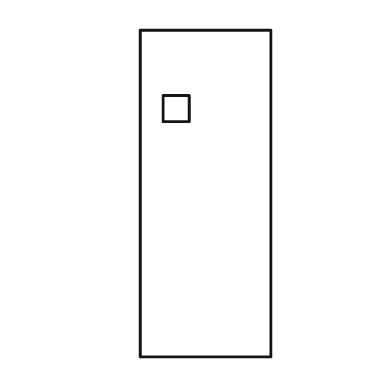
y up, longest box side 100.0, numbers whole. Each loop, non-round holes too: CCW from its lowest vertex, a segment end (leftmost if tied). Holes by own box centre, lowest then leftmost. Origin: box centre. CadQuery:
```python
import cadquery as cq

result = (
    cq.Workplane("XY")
    .moveTo(-20.0, -50.0)
    .lineTo(20.0, -50.0)
    .lineTo(20.0, 50.0)
    .lineTo(-20.0, 50.0)
    .close()
    .moveTo(-13.0, 22.0)
    .lineTo(-5.0, 22.0)
    .lineTo(-5.0, 30.0)
    .lineTo(-13.0, 30.0)
    .close()
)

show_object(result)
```